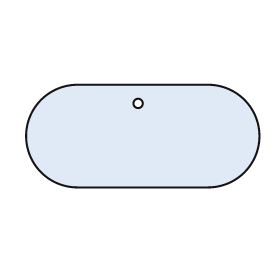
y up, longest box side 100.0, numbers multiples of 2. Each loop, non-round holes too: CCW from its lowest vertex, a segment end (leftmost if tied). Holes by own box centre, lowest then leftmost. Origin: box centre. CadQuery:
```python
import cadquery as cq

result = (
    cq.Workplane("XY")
    .moveTo(-28.0, -22.0)
    .lineTo(28.0, -22.0)
    .threePointArc((50.0, 0.0), (28.0, 22.0))
    .lineTo(-28.0, 22.0)
    .threePointArc((-50.0, 0.0), (-28.0, -22.0))
    .close()
    .moveTo(-2.0, 14.0)
    .circle(2.0)
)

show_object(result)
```